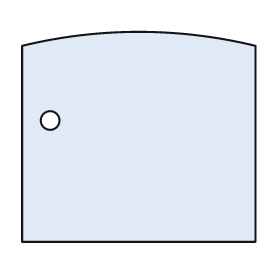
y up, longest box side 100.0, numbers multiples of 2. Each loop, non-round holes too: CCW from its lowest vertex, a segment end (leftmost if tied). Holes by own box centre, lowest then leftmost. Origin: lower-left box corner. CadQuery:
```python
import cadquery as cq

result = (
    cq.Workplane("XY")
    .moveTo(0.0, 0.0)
    .lineTo(100.0, 0.0)
    .lineTo(100.0, 84.0)
    .threePointArc((50.0, 90.0), (0.0, 84.0))
    .close()
    .moveTo(12.0, 52.0)
    .circle(4.0)
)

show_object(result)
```